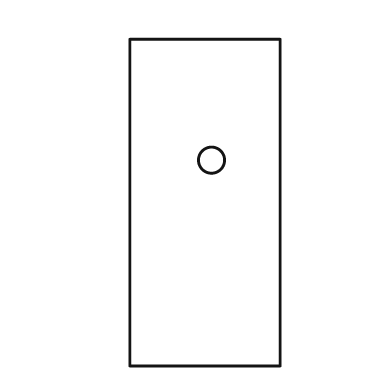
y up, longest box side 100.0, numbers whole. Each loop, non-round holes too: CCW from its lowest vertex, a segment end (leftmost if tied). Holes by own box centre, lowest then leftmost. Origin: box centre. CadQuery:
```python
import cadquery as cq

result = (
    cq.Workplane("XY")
    .moveTo(-23.0, -50.0)
    .lineTo(23.0, -50.0)
    .lineTo(23.0, 50.0)
    .lineTo(-23.0, 50.0)
    .close()
    .moveTo(2.0, 13.0)
    .circle(4.0)
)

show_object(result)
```